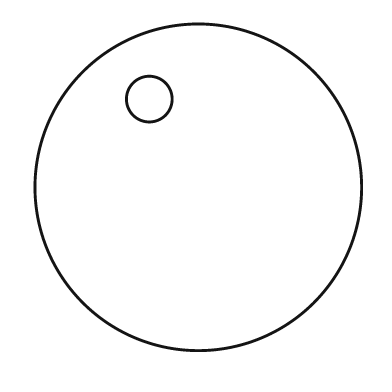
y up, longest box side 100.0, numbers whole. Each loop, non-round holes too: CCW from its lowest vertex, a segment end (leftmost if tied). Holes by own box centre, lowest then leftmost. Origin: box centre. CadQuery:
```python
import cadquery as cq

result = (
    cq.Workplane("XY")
    .moveTo(0.0, 0.0)
    .circle(50.0)
    .moveTo(-15.0, 27.0)
    .circle(7.0)
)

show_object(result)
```